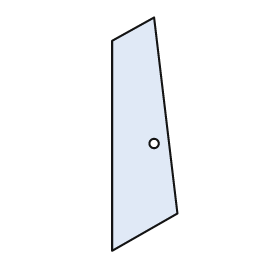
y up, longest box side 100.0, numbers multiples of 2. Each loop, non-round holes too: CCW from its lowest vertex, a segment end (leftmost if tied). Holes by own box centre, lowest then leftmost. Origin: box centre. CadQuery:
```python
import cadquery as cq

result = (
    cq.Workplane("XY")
    .moveTo(-14.0, -50.0)
    .lineTo(14.0, -34.0)
    .lineTo(4.0, 50.0)
    .lineTo(-14.0, 40.0)
    .close()
    .moveTo(4.0, -4.0)
    .circle(2.0)
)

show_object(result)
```